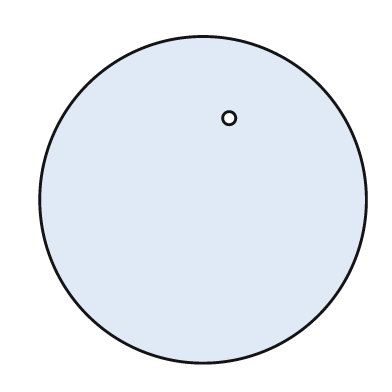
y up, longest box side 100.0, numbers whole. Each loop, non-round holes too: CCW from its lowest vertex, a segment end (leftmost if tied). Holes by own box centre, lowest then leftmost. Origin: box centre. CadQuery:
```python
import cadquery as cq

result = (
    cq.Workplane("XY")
    .moveTo(0.0, 0.0)
    .circle(50.0)
    .moveTo(8.0, 25.0)
    .circle(2.0)
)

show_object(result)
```